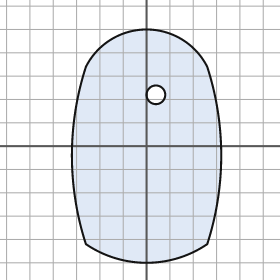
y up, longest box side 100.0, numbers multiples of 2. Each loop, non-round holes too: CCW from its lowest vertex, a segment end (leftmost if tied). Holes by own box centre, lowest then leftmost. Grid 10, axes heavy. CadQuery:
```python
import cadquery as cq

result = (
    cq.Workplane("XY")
    .moveTo(-26.0, -42.0)
    .threePointArc((0.0, -50.0), (26.0, -42.0))
    .threePointArc((32.0, -4.0), (26.0, 34.0))
    .threePointArc((0.0, 50.0), (-26.0, 34.0))
    .threePointArc((-32.0, -4.0), (-26.0, -42.0))
    .close()
    .moveTo(4.0, 22.0)
    .circle(4.0)
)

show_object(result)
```